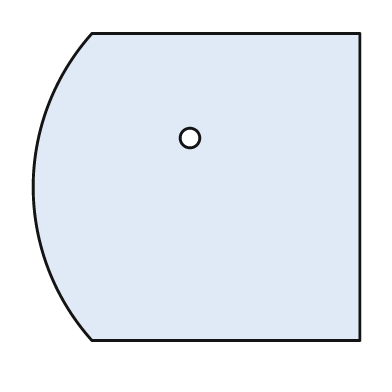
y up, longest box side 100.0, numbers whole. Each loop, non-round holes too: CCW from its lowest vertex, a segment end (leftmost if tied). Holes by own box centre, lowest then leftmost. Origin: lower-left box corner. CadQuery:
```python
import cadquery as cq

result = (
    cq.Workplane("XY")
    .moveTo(18.0, 0.0)
    .lineTo(100.0, 0.0)
    .lineTo(100.0, 94.0)
    .lineTo(18.0, 94.0)
    .threePointArc((0.0, 47.0), (18.0, 0.0))
    .close()
    .moveTo(48.0, 62.0)
    .circle(3.0)
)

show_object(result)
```